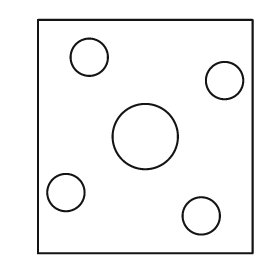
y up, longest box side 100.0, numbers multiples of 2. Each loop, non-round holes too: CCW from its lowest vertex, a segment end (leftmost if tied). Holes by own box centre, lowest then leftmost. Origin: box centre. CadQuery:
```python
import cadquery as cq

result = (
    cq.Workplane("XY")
    .moveTo(-46.0, -50.0)
    .lineTo(46.0, -50.0)
    .lineTo(46.0, 50.0)
    .lineTo(-46.0, 50.0)
    .close()
    .moveTo(24.0, -34.0)
    .circle(8.0)
    .moveTo(-34.0, -24.0)
    .circle(8.0)
    .moveTo(0.0, 0.0)
    .circle(14.0)
    .moveTo(34.0, 24.0)
    .circle(8.0)
    .moveTo(-24.0, 34.0)
    .circle(8.0)
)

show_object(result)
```